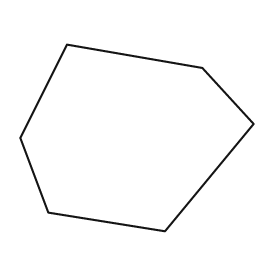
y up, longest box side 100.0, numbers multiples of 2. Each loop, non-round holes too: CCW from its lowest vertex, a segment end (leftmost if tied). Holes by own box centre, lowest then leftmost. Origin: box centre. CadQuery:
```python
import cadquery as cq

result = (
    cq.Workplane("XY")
    .moveTo(12.0, -40.0)
    .lineTo(50.0, 6.0)
    .lineTo(28.0, 30.0)
    .lineTo(-30.0, 40.0)
    .lineTo(-50.0, 0.0)
    .lineTo(-38.0, -32.0)
    .close()
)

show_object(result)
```